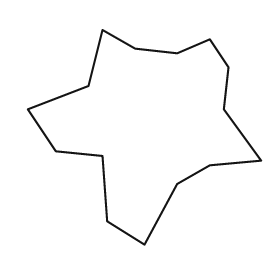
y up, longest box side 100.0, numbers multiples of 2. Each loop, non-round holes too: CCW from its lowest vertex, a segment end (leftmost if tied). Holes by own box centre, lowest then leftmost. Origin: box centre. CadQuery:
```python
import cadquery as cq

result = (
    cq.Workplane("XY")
    .moveTo(0.0, -46.0)
    .lineTo(14.0, -20.0)
    .lineTo(28.0, -12.0)
    .lineTo(50.0, -10.0)
    .lineTo(34.0, 12.0)
    .lineTo(36.0, 30.0)
    .lineTo(28.0, 42.0)
    .lineTo(14.0, 36.0)
    .lineTo(-4.0, 38.0)
    .lineTo(-18.0, 46.0)
    .lineTo(-24.0, 22.0)
    .lineTo(-50.0, 12.0)
    .lineTo(-38.0, -6.0)
    .lineTo(-18.0, -8.0)
    .lineTo(-16.0, -36.0)
    .close()
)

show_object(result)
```